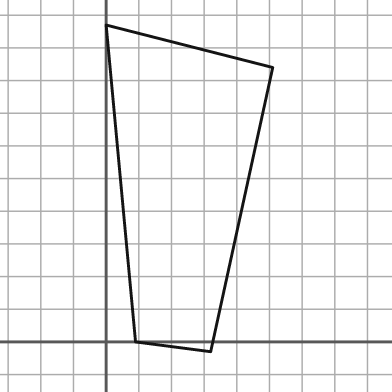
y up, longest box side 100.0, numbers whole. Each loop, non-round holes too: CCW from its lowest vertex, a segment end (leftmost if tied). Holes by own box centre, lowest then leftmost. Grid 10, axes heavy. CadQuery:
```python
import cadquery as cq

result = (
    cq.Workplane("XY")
    .moveTo(32.0, -3.0)
    .lineTo(51.0, 84.0)
    .lineTo(0.0, 97.0)
    .lineTo(9.0, 0.0)
    .close()
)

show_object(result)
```